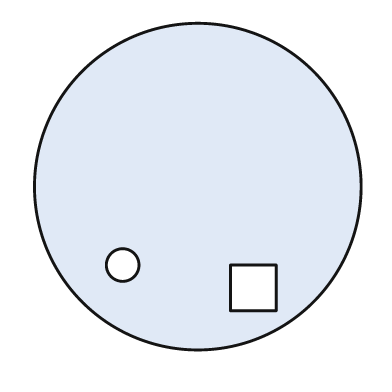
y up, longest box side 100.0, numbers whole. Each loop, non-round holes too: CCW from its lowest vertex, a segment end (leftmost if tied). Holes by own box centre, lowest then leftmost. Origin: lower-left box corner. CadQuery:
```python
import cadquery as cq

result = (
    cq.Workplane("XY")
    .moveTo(50.0, 50.0)
    .circle(50.0)
    .moveTo(60.0, 12.0)
    .lineTo(74.0, 12.0)
    .lineTo(74.0, 26.0)
    .lineTo(60.0, 26.0)
    .close()
    .moveTo(27.0, 26.0)
    .circle(5.0)
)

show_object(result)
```